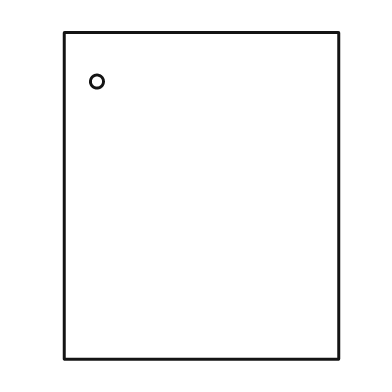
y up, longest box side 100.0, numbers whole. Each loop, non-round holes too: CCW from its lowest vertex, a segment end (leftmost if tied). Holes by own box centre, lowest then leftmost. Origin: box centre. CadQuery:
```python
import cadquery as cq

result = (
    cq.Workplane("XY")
    .moveTo(-42.0, -50.0)
    .lineTo(42.0, -50.0)
    .lineTo(42.0, 50.0)
    .lineTo(-42.0, 50.0)
    .close()
    .moveTo(-32.0, 35.0)
    .circle(2.0)
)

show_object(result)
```